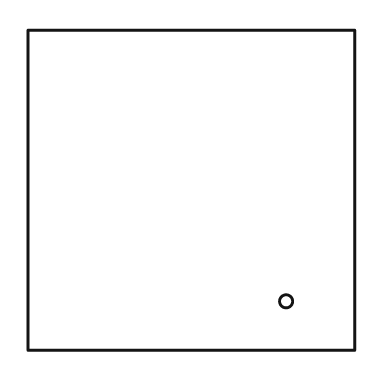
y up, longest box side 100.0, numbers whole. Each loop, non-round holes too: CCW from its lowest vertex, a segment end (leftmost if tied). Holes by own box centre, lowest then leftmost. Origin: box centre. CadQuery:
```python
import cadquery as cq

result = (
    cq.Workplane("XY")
    .moveTo(-50.0, -49.0)
    .lineTo(50.0, -49.0)
    .lineTo(50.0, 49.0)
    .lineTo(-50.0, 49.0)
    .close()
    .moveTo(29.0, -34.0)
    .circle(2.0)
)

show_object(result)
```